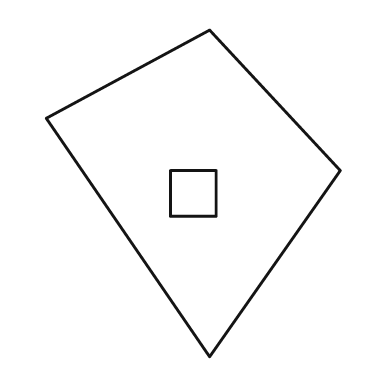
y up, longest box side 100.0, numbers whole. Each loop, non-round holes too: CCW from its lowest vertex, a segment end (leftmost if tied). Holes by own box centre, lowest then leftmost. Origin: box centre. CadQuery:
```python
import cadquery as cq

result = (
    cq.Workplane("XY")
    .moveTo(5.0, -50.0)
    .lineTo(45.0, 7.0)
    .lineTo(5.0, 50.0)
    .lineTo(-45.0, 23.0)
    .close()
    .moveTo(-7.0, -7.0)
    .lineTo(7.0, -7.0)
    .lineTo(7.0, 7.0)
    .lineTo(-7.0, 7.0)
    .close()
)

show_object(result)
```